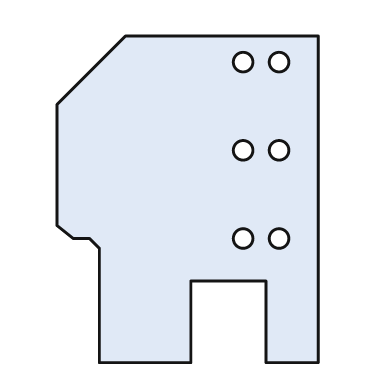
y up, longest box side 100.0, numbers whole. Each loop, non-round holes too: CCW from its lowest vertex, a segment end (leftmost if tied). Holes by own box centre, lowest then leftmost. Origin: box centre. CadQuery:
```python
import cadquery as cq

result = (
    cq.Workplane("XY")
    .moveTo(-27.0, -50.0)
    .lineTo(1.0, -50.0)
    .lineTo(1.0, -25.0)
    .lineTo(24.0, -25.0)
    .lineTo(24.0, -50.0)
    .lineTo(40.0, -50.0)
    .lineTo(40.0, 50.0)
    .lineTo(-19.0, 50.0)
    .lineTo(-40.0, 29.0)
    .lineTo(-40.0, -8.0)
    .lineTo(-35.0, -12.0)
    .lineTo(-30.0, -12.0)
    .lineTo(-27.0, -15.0)
    .close()
    .moveTo(17.0, -12.0)
    .circle(3.0)
    .moveTo(28.0, -12.0)
    .circle(3.0)
    .moveTo(17.0, 15.0)
    .circle(3.0)
    .moveTo(28.0, 15.0)
    .circle(3.0)
    .moveTo(17.0, 42.0)
    .circle(3.0)
    .moveTo(28.0, 42.0)
    .circle(3.0)
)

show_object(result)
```